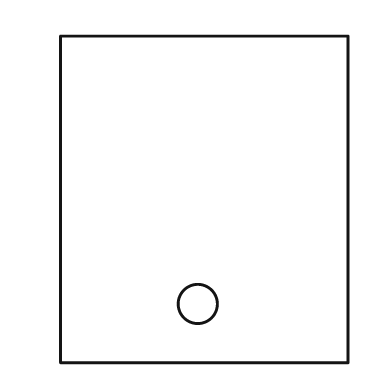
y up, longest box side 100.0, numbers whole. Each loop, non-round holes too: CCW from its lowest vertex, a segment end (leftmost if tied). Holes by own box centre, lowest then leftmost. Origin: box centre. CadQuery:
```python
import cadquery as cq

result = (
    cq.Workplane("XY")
    .moveTo(-44.0, -50.0)
    .lineTo(44.0, -50.0)
    .lineTo(44.0, 50.0)
    .lineTo(-44.0, 50.0)
    .close()
    .moveTo(-2.0, -32.0)
    .circle(6.0)
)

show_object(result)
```